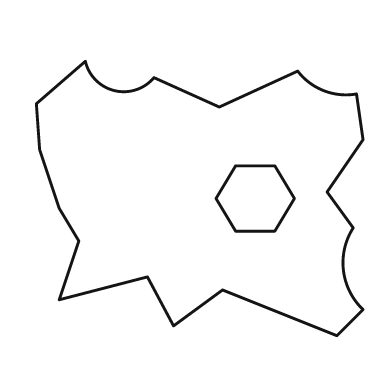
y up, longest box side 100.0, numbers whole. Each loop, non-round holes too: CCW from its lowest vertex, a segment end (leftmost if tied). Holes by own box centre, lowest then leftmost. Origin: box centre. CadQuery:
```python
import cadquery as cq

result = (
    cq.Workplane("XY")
    .moveTo(42.0, -42.0)
    .lineTo(50.0, -34.0)
    .threePointArc((44.0, -22.0), (47.0, -9.0))
    .lineTo(39.0, 2.0)
    .lineTo(50.0, 18.0)
    .lineTo(48.0, 32.0)
    .threePointArc((38.0, 33.0), (30.0, 39.0))
    .lineTo(6.0, 28.0)
    .lineTo(-14.0, 37.0)
    .threePointArc((-26.0, 33.0), (-35.0, 42.0))
    .lineTo(-50.0, 29.0)
    .lineTo(-49.0, 15.0)
    .lineTo(-43.0, -3.0)
    .lineTo(-37.0, -13.0)
    .lineTo(-43.0, -31.0)
    .lineTo(-16.0, -24.0)
    .lineTo(-8.0, -39.0)
    .lineTo(7.0, -28.0)
    .close()
    .moveTo(11.0, -10.0)
    .lineTo(23.0, -10.0)
    .lineTo(29.0, 0.0)
    .lineTo(23.0, 10.0)
    .lineTo(11.0, 10.0)
    .lineTo(5.0, 0.0)
    .close()
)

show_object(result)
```